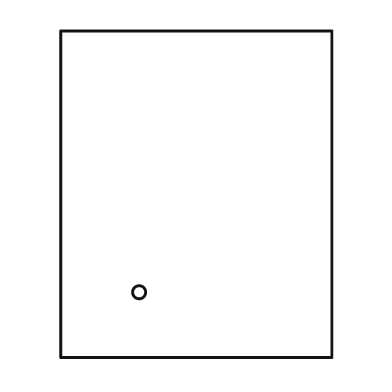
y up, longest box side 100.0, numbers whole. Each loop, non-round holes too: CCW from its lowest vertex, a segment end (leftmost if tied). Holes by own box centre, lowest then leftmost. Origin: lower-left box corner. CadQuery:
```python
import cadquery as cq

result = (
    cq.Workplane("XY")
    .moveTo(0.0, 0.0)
    .lineTo(83.0, 0.0)
    .lineTo(83.0, 100.0)
    .lineTo(0.0, 100.0)
    .close()
    .moveTo(24.0, 20.0)
    .circle(2.0)
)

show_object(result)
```